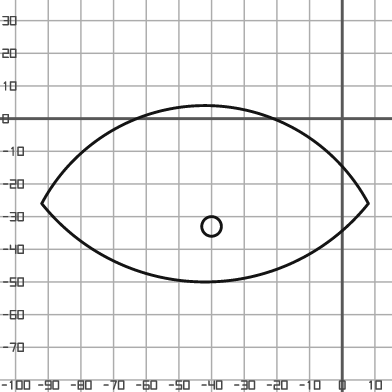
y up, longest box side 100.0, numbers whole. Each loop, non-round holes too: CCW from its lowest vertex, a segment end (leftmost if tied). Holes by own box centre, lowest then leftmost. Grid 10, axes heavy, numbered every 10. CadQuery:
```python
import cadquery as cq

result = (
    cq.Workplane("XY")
    .moveTo(-92.0, -26.0)
    .threePointArc((-42.0, -50.0), (8.0, -26.0))
    .threePointArc((-42.0, 4.0), (-92.0, -26.0))
    .close()
    .moveTo(-40.0, -33.0)
    .circle(3.0)
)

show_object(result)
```